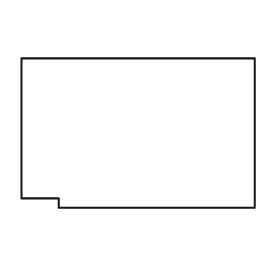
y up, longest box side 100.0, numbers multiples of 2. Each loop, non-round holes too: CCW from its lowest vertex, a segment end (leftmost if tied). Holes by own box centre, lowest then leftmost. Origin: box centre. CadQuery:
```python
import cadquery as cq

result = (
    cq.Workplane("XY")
    .moveTo(-34.0, -32.0)
    .lineTo(50.0, -32.0)
    .lineTo(50.0, 32.0)
    .lineTo(-50.0, 32.0)
    .lineTo(-50.0, -28.0)
    .lineTo(-34.0, -28.0)
    .close()
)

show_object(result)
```